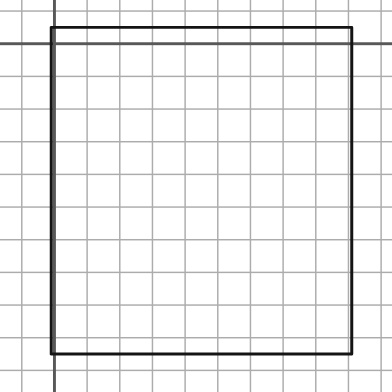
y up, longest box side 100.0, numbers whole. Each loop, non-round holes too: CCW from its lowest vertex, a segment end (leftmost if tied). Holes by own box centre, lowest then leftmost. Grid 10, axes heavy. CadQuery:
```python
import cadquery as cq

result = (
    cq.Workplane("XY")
    .moveTo(-1.0, -95.0)
    .lineTo(91.0, -95.0)
    .lineTo(91.0, 5.0)
    .lineTo(-1.0, 5.0)
    .close()
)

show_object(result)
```